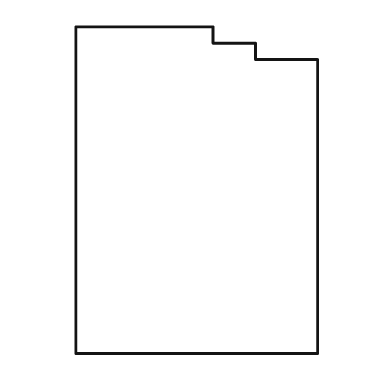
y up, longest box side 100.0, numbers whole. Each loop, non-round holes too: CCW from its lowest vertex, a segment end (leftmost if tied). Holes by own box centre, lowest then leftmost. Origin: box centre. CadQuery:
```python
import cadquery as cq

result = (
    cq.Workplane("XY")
    .moveTo(-37.0, -50.0)
    .lineTo(37.0, -50.0)
    .lineTo(37.0, 40.0)
    .lineTo(18.0, 40.0)
    .lineTo(18.0, 45.0)
    .lineTo(5.0, 45.0)
    .lineTo(5.0, 50.0)
    .lineTo(-37.0, 50.0)
    .close()
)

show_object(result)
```